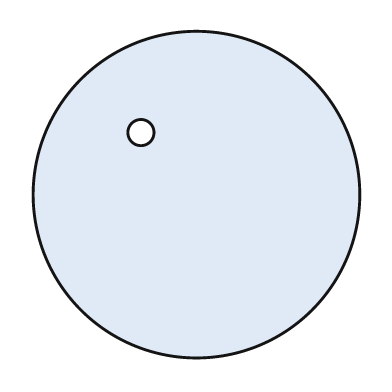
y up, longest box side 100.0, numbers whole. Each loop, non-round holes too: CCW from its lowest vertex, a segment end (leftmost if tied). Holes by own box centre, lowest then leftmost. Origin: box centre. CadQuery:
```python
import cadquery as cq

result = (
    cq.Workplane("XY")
    .moveTo(0.0, 0.0)
    .circle(50.0)
    .moveTo(-17.0, 19.0)
    .circle(4.0)
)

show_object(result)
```